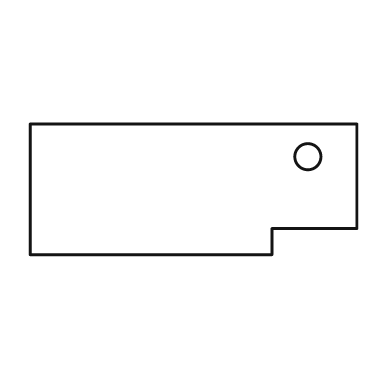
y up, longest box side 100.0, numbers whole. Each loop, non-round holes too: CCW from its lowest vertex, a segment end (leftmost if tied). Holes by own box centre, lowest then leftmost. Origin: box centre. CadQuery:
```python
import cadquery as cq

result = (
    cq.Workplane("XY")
    .moveTo(-50.0, -20.0)
    .lineTo(24.0, -20.0)
    .lineTo(24.0, -12.0)
    .lineTo(50.0, -12.0)
    .lineTo(50.0, 20.0)
    .lineTo(-50.0, 20.0)
    .close()
    .moveTo(35.0, 10.0)
    .circle(4.0)
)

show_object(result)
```